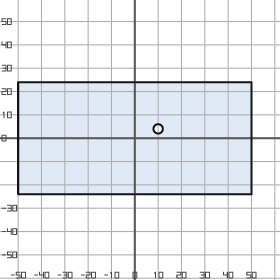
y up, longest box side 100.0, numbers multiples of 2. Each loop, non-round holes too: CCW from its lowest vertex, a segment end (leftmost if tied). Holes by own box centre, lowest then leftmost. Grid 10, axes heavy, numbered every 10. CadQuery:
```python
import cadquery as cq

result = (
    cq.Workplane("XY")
    .moveTo(-50.0, -24.0)
    .lineTo(50.0, -24.0)
    .lineTo(50.0, 24.0)
    .lineTo(-50.0, 24.0)
    .close()
    .moveTo(10.0, 4.0)
    .circle(2.0)
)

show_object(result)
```